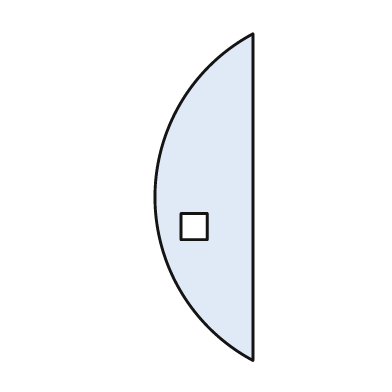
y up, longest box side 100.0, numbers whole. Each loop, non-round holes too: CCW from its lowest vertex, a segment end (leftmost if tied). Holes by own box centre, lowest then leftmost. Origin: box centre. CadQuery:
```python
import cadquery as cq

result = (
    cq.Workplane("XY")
    .moveTo(15.0, -50.0)
    .lineTo(15.0, 50.0)
    .threePointArc((-15.0, 0.0), (15.0, -50.0))
    .close()
    .moveTo(-7.0, -13.0)
    .lineTo(1.0, -13.0)
    .lineTo(1.0, -5.0)
    .lineTo(-7.0, -5.0)
    .close()
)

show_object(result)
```